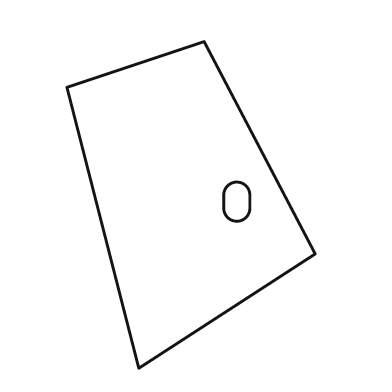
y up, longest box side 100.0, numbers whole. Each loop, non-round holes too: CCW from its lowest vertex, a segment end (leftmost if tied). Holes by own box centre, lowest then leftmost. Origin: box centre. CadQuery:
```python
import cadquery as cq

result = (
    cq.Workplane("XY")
    .moveTo(-16.0, -50.0)
    .lineTo(38.0, -15.0)
    .lineTo(4.0, 50.0)
    .lineTo(-38.0, 36.0)
    .close()
    .moveTo(10.0, -1.0)
    .threePointArc((14.0, -5.0), (18.0, -1.0))
    .lineTo(18.0, 3.0)
    .threePointArc((14.0, 7.0), (10.0, 3.0))
    .close()
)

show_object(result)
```